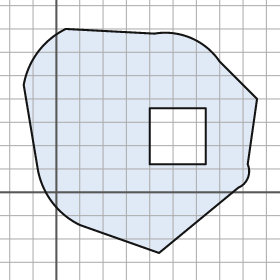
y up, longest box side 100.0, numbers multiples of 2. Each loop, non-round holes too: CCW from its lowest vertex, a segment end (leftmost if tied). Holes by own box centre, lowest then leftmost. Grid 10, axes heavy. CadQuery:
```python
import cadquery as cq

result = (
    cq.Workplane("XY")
    .moveTo(44.0, -26.0)
    .lineTo(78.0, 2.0)
    .threePointArc((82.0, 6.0), (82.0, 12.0))
    .lineTo(86.0, 40.0)
    .lineTo(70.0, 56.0)
    .threePointArc((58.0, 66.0), (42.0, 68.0))
    .lineTo(4.0, 70.0)
    .threePointArc((-8.0, 60.0), (-14.0, 46.0))
    .lineTo(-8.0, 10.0)
    .threePointArc((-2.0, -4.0), (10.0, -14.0))
    .close()
    .moveTo(40.0, 12.0)
    .lineTo(64.0, 12.0)
    .lineTo(64.0, 36.0)
    .lineTo(40.0, 36.0)
    .close()
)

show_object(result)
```